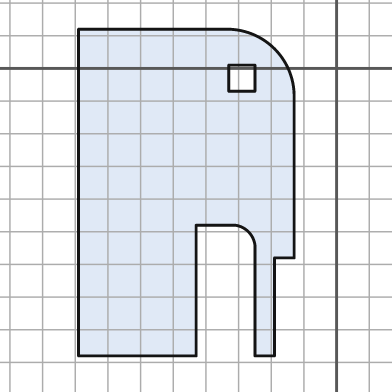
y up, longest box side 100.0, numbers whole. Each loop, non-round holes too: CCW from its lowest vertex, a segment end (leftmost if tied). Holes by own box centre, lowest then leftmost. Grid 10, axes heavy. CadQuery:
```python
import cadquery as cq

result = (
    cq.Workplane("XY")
    .moveTo(-79.0, -88.0)
    .lineTo(-43.0, -88.0)
    .lineTo(-43.0, -48.0)
    .lineTo(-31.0, -48.0)
    .threePointArc((-27.0, -50.0), (-25.0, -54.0))
    .lineTo(-25.0, -88.0)
    .lineTo(-19.0, -88.0)
    .lineTo(-19.0, -58.0)
    .lineTo(-13.0, -58.0)
    .lineTo(-13.0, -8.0)
    .threePointArc((-19.0, 6.0), (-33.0, 12.0))
    .lineTo(-79.0, 12.0)
    .close()
    .moveTo(-33.0, -7.0)
    .lineTo(-25.0, -7.0)
    .lineTo(-25.0, 1.0)
    .lineTo(-33.0, 1.0)
    .close()
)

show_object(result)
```